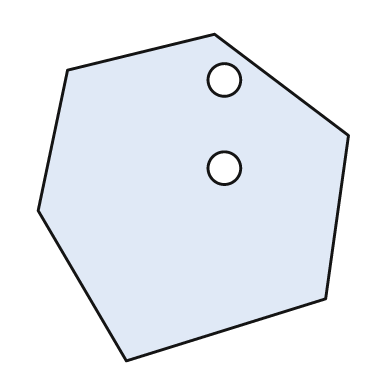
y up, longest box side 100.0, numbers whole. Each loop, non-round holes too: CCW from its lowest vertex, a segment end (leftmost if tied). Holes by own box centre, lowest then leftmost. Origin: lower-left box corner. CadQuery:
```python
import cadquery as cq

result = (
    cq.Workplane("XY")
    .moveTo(27.0, 0.0)
    .lineTo(88.0, 19.0)
    .lineTo(95.0, 69.0)
    .lineTo(54.0, 100.0)
    .lineTo(9.0, 89.0)
    .lineTo(0.0, 46.0)
    .close()
    .moveTo(57.0, 59.0)
    .circle(5.0)
    .moveTo(57.0, 86.0)
    .circle(5.0)
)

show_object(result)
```